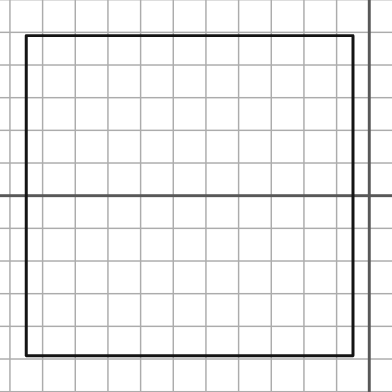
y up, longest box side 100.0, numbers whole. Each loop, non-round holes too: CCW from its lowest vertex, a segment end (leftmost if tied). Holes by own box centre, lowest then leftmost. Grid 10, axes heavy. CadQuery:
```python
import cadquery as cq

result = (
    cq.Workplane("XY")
    .moveTo(-105.0, -49.0)
    .lineTo(-5.0, -49.0)
    .lineTo(-5.0, 49.0)
    .lineTo(-105.0, 49.0)
    .close()
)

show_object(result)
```